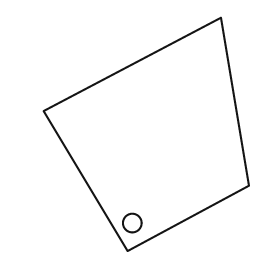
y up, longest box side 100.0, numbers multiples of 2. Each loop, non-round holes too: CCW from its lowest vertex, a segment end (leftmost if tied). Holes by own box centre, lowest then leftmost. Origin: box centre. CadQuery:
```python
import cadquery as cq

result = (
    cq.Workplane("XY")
    .moveTo(-8.0, -50.0)
    .lineTo(44.0, -22.0)
    .lineTo(32.0, 50.0)
    .lineTo(-44.0, 10.0)
    .close()
    .moveTo(-6.0, -38.0)
    .circle(4.0)
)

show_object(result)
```